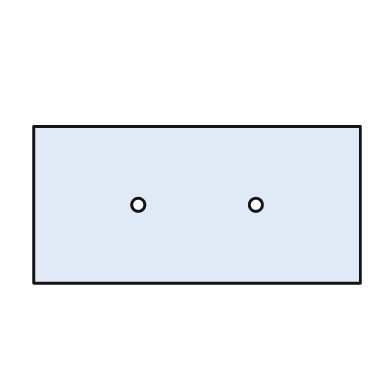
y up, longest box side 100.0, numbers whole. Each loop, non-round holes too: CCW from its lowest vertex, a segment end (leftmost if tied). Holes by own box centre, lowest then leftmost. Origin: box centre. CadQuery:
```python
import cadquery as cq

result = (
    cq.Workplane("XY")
    .moveTo(-50.0, -24.0)
    .lineTo(50.0, -24.0)
    .lineTo(50.0, 24.0)
    .lineTo(-50.0, 24.0)
    .close()
    .moveTo(-18.0, 0.0)
    .circle(2.0)
    .moveTo(18.0, 0.0)
    .circle(2.0)
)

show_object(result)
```